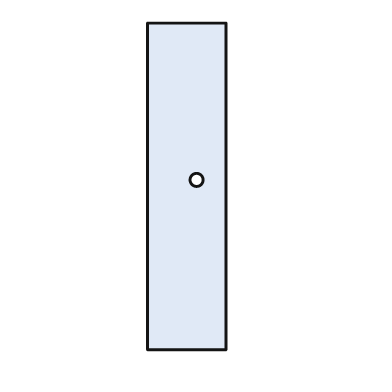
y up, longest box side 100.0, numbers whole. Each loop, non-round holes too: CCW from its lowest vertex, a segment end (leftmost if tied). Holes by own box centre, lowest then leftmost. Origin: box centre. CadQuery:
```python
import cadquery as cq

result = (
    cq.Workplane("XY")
    .moveTo(-12.0, -50.0)
    .lineTo(12.0, -50.0)
    .lineTo(12.0, 50.0)
    .lineTo(-12.0, 50.0)
    .close()
    .moveTo(3.0, 2.0)
    .circle(2.0)
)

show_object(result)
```